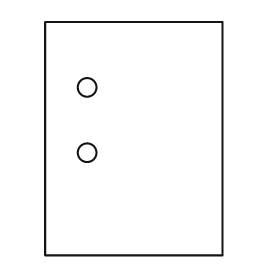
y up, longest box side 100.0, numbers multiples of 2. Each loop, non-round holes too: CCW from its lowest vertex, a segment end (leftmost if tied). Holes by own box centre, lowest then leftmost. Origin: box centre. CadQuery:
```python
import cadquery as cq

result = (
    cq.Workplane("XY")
    .moveTo(-38.0, -50.0)
    .lineTo(38.0, -50.0)
    .lineTo(38.0, 50.0)
    .lineTo(-38.0, 50.0)
    .close()
    .moveTo(-20.0, -6.0)
    .circle(4.0)
    .moveTo(-20.0, 22.0)
    .circle(4.0)
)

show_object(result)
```